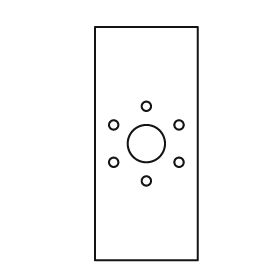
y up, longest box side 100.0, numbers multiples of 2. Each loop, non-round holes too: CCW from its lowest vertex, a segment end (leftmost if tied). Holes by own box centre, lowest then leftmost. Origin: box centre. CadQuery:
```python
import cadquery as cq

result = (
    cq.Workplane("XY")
    .moveTo(-22.0, -50.0)
    .lineTo(22.0, -50.0)
    .lineTo(22.0, 50.0)
    .lineTo(-22.0, 50.0)
    .close()
    .moveTo(0.0, -16.0)
    .circle(2.0)
    .moveTo(-14.0, -8.0)
    .circle(2.0)
    .moveTo(14.0, -8.0)
    .circle(2.0)
    .moveTo(0.0, 0.0)
    .circle(8.0)
    .moveTo(-14.0, 8.0)
    .circle(2.0)
    .moveTo(14.0, 8.0)
    .circle(2.0)
    .moveTo(0.0, 16.0)
    .circle(2.0)
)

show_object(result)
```